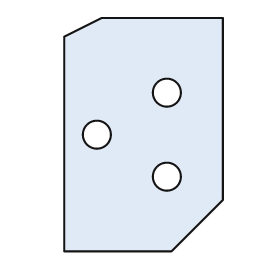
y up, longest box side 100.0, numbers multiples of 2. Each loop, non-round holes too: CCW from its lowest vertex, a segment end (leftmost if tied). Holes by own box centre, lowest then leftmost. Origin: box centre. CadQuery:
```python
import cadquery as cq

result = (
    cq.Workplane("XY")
    .moveTo(-34.0, -50.0)
    .lineTo(12.0, -50.0)
    .lineTo(34.0, -28.0)
    .lineTo(34.0, 50.0)
    .lineTo(-18.0, 50.0)
    .lineTo(-34.0, 42.0)
    .close()
    .moveTo(10.0, -18.0)
    .circle(6.0)
    .moveTo(-20.0, 0.0)
    .circle(6.0)
    .moveTo(10.0, 18.0)
    .circle(6.0)
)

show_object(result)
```